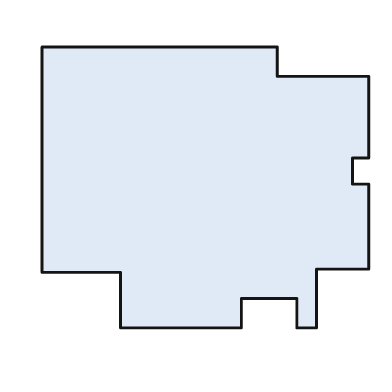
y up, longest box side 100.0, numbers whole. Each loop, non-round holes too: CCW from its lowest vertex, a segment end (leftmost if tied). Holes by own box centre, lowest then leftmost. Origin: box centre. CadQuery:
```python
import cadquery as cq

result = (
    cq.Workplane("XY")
    .moveTo(-26.0, -43.0)
    .lineTo(11.0, -43.0)
    .lineTo(11.0, -34.0)
    .lineTo(28.0, -34.0)
    .lineTo(28.0, -43.0)
    .lineTo(34.0, -43.0)
    .lineTo(34.0, -25.0)
    .lineTo(50.0, -25.0)
    .lineTo(50.0, 1.0)
    .lineTo(45.0, 1.0)
    .lineTo(45.0, 9.0)
    .lineTo(50.0, 9.0)
    .lineTo(50.0, 34.0)
    .lineTo(22.0, 34.0)
    .lineTo(22.0, 43.0)
    .lineTo(-50.0, 43.0)
    .lineTo(-50.0, -26.0)
    .lineTo(-26.0, -26.0)
    .close()
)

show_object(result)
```